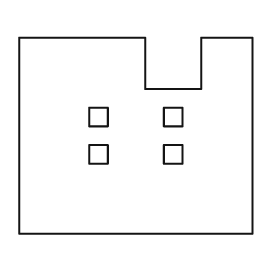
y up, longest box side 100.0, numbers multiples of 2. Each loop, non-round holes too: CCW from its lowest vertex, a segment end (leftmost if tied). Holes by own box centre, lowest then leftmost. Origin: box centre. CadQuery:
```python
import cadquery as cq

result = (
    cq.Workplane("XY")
    .moveTo(-50.0, -42.0)
    .lineTo(50.0, -42.0)
    .lineTo(50.0, 42.0)
    .lineTo(28.0, 42.0)
    .lineTo(28.0, 20.0)
    .lineTo(4.0, 20.0)
    .lineTo(4.0, 42.0)
    .lineTo(-50.0, 42.0)
    .close()
    .moveTo(-20.0, -12.0)
    .lineTo(-12.0, -12.0)
    .lineTo(-12.0, -4.0)
    .lineTo(-20.0, -4.0)
    .close()
    .moveTo(12.0, -12.0)
    .lineTo(20.0, -12.0)
    .lineTo(20.0, -4.0)
    .lineTo(12.0, -4.0)
    .close()
    .moveTo(-20.0, 4.0)
    .lineTo(-12.0, 4.0)
    .lineTo(-12.0, 12.0)
    .lineTo(-20.0, 12.0)
    .close()
    .moveTo(12.0, 4.0)
    .lineTo(20.0, 4.0)
    .lineTo(20.0, 12.0)
    .lineTo(12.0, 12.0)
    .close()
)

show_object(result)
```